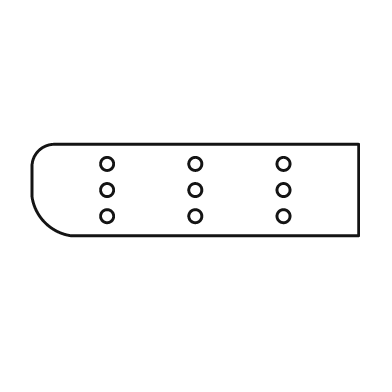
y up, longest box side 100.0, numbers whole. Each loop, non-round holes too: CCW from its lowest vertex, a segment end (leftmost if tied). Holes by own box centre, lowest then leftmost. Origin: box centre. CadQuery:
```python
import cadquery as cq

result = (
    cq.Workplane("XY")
    .moveTo(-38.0, -14.0)
    .lineTo(50.0, -14.0)
    .lineTo(50.0, 14.0)
    .lineTo(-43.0, 14.0)
    .threePointArc((-48.0, 12.0), (-50.0, 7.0))
    .lineTo(-50.0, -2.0)
    .threePointArc((-46.0, -10.0), (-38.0, -14.0))
    .close()
    .moveTo(-27.0, -8.0)
    .circle(2.0)
    .moveTo(0.0, -8.0)
    .circle(2.0)
    .moveTo(27.0, -8.0)
    .circle(2.0)
    .moveTo(-27.0, 0.0)
    .circle(2.0)
    .moveTo(0.0, 0.0)
    .circle(2.0)
    .moveTo(27.0, 0.0)
    .circle(2.0)
    .moveTo(-27.0, 8.0)
    .circle(2.0)
    .moveTo(0.0, 8.0)
    .circle(2.0)
    .moveTo(27.0, 8.0)
    .circle(2.0)
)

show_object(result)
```